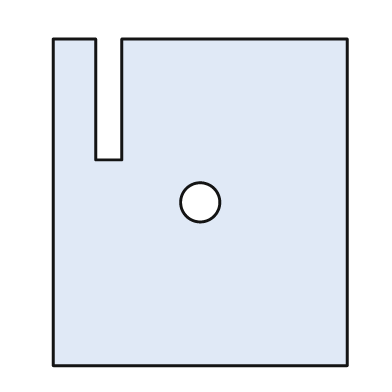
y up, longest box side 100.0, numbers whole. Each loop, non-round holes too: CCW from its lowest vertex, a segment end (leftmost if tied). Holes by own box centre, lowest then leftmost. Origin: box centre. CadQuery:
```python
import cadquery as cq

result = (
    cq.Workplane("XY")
    .moveTo(-45.0, -50.0)
    .lineTo(45.0, -50.0)
    .lineTo(45.0, 50.0)
    .lineTo(-24.0, 50.0)
    .lineTo(-24.0, 13.0)
    .lineTo(-32.0, 13.0)
    .lineTo(-32.0, 50.0)
    .lineTo(-45.0, 50.0)
    .close()
    .moveTo(0.0, 0.0)
    .circle(6.0)
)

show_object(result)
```